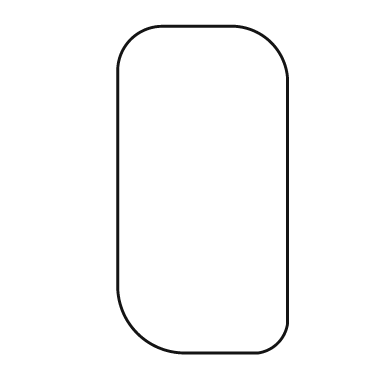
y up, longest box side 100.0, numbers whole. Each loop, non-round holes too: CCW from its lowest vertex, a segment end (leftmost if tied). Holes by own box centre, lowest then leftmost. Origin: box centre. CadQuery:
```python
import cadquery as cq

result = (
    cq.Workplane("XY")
    .moveTo(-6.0, -50.0)
    .lineTo(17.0, -50.0)
    .threePointArc((23.0, -47.0), (26.0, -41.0))
    .lineTo(26.0, 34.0)
    .threePointArc((21.0, 45.0), (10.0, 50.0))
    .lineTo(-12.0, 50.0)
    .threePointArc((-22.0, 46.0), (-26.0, 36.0))
    .lineTo(-26.0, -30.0)
    .threePointArc((-20.0, -44.0), (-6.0, -50.0))
    .close()
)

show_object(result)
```